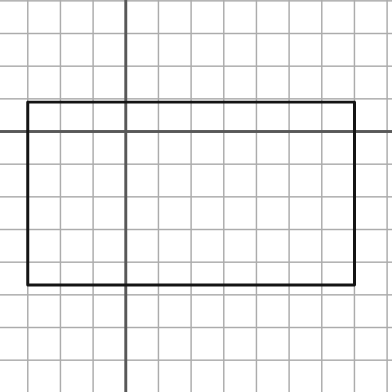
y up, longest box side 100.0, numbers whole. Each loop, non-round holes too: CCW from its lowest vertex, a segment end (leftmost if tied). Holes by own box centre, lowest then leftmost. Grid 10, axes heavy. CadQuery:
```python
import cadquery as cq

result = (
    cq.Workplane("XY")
    .moveTo(-30.0, -47.0)
    .lineTo(70.0, -47.0)
    .lineTo(70.0, 9.0)
    .lineTo(-30.0, 9.0)
    .close()
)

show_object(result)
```